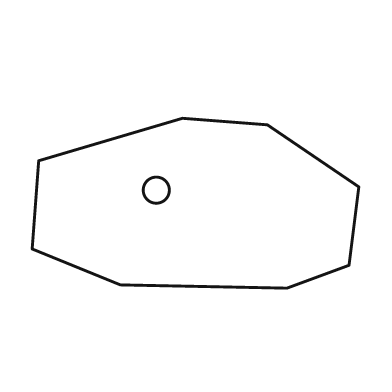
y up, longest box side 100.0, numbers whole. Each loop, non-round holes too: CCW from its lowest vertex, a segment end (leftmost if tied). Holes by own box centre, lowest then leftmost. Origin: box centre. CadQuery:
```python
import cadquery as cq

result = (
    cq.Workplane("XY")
    .moveTo(28.0, -26.0)
    .lineTo(47.0, -19.0)
    .lineTo(50.0, 5.0)
    .lineTo(22.0, 24.0)
    .lineTo(-4.0, 26.0)
    .lineTo(-48.0, 13.0)
    .lineTo(-50.0, -14.0)
    .lineTo(-23.0, -25.0)
    .close()
    .moveTo(-12.0, 4.0)
    .circle(4.0)
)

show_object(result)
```